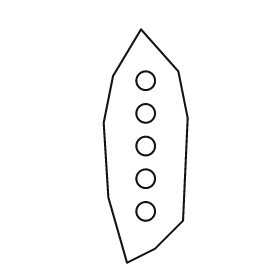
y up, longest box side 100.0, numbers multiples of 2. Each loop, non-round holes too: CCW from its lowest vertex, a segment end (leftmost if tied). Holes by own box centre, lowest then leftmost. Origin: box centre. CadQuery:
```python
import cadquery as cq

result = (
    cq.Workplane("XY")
    .moveTo(-8.0, -50.0)
    .lineTo(4.0, -44.0)
    .lineTo(16.0, -32.0)
    .lineTo(18.0, 12.0)
    .lineTo(14.0, 32.0)
    .lineTo(-2.0, 50.0)
    .lineTo(-14.0, 30.0)
    .lineTo(-18.0, 10.0)
    .lineTo(-16.0, -22.0)
    .close()
    .moveTo(0.0, -28.0)
    .circle(4.0)
    .moveTo(0.0, -14.0)
    .circle(4.0)
    .moveTo(0.0, 0.0)
    .circle(4.0)
    .moveTo(0.0, 14.0)
    .circle(4.0)
    .moveTo(0.0, 28.0)
    .circle(4.0)
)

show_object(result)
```